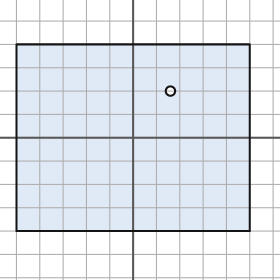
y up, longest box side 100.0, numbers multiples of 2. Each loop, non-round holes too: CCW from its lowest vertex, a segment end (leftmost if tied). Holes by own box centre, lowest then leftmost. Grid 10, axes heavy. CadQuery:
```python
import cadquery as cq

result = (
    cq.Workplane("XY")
    .moveTo(-50.0, -40.0)
    .lineTo(50.0, -40.0)
    .lineTo(50.0, 40.0)
    .lineTo(-50.0, 40.0)
    .close()
    .moveTo(16.0, 20.0)
    .circle(2.0)
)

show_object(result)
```